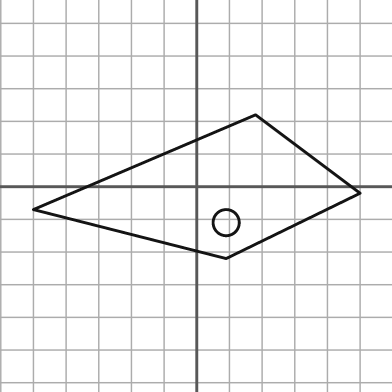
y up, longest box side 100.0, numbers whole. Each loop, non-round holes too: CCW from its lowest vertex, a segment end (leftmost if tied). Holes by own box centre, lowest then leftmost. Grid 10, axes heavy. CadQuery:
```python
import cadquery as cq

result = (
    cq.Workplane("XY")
    .moveTo(9.0, -22.0)
    .lineTo(50.0, -2.0)
    .lineTo(18.0, 22.0)
    .lineTo(-50.0, -7.0)
    .close()
    .moveTo(9.0, -11.0)
    .circle(4.0)
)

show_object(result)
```